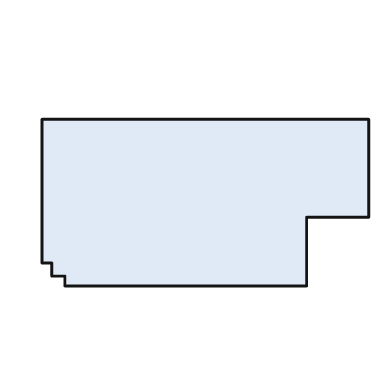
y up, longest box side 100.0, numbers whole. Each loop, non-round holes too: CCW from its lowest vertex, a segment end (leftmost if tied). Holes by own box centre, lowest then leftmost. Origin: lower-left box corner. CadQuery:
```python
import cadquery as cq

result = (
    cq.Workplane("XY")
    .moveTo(7.0, 0.0)
    .lineTo(81.0, 0.0)
    .lineTo(81.0, 21.0)
    .lineTo(100.0, 21.0)
    .lineTo(100.0, 51.0)
    .lineTo(0.0, 51.0)
    .lineTo(0.0, 7.0)
    .lineTo(3.0, 7.0)
    .lineTo(3.0, 3.0)
    .lineTo(7.0, 3.0)
    .close()
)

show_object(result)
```